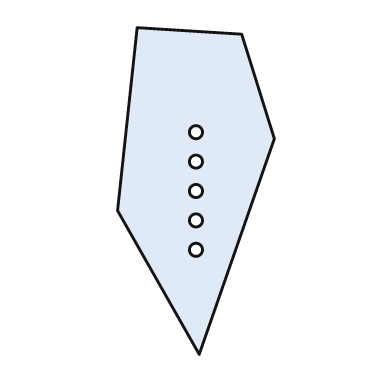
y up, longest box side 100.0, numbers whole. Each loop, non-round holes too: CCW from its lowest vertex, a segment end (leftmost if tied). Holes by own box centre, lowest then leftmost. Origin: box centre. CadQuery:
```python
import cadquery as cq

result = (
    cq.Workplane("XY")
    .moveTo(1.0, -50.0)
    .lineTo(24.0, 16.0)
    .lineTo(14.0, 48.0)
    .lineTo(-18.0, 50.0)
    .lineTo(-24.0, -6.0)
    .close()
    .moveTo(0.0, -18.0)
    .circle(2.0)
    .moveTo(0.0, -9.0)
    .circle(2.0)
    .moveTo(0.0, 0.0)
    .circle(2.0)
    .moveTo(0.0, 9.0)
    .circle(2.0)
    .moveTo(0.0, 18.0)
    .circle(2.0)
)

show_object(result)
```